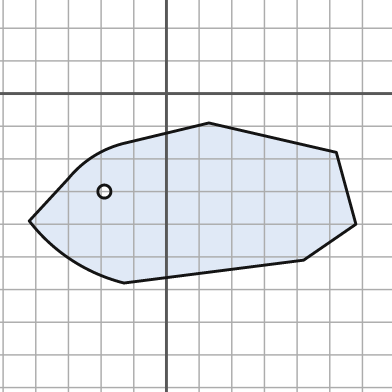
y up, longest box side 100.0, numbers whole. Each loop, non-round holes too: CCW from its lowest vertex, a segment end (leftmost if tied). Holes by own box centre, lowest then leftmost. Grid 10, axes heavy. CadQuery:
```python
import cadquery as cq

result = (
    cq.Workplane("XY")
    .moveTo(-13.0, -58.0)
    .lineTo(42.0, -51.0)
    .lineTo(58.0, -40.0)
    .lineTo(52.0, -18.0)
    .lineTo(13.0, -9.0)
    .lineTo(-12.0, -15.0)
    .threePointArc((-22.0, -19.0), (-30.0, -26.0))
    .lineTo(-42.0, -39.0)
    .threePointArc((-29.0, -51.0), (-13.0, -58.0))
    .close()
    .moveTo(-19.0, -30.0)
    .circle(2.0)
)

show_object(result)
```